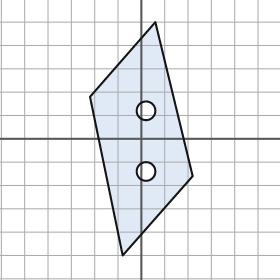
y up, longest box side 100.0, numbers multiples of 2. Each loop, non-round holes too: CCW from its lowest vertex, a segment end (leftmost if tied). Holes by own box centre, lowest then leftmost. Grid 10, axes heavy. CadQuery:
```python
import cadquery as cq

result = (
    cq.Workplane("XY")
    .moveTo(-8.0, -50.0)
    .lineTo(22.0, -16.0)
    .lineTo(6.0, 50.0)
    .lineTo(-22.0, 18.0)
    .close()
    .moveTo(2.0, -14.0)
    .circle(4.0)
    .moveTo(2.0, 12.0)
    .circle(4.0)
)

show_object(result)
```